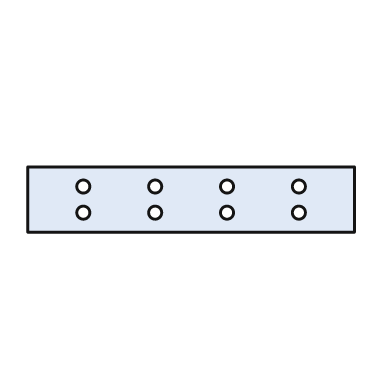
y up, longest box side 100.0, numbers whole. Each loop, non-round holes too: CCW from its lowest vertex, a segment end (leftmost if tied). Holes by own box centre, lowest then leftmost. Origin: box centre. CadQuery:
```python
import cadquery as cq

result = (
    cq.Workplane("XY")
    .moveTo(-50.0, -10.0)
    .lineTo(50.0, -10.0)
    .lineTo(50.0, 10.0)
    .lineTo(-50.0, 10.0)
    .close()
    .moveTo(-33.0, -4.0)
    .circle(2.0)
    .moveTo(-11.0, -4.0)
    .circle(2.0)
    .moveTo(11.0, -4.0)
    .circle(2.0)
    .moveTo(33.0, -4.0)
    .circle(2.0)
    .moveTo(-33.0, 4.0)
    .circle(2.0)
    .moveTo(-11.0, 4.0)
    .circle(2.0)
    .moveTo(11.0, 4.0)
    .circle(2.0)
    .moveTo(33.0, 4.0)
    .circle(2.0)
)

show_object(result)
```